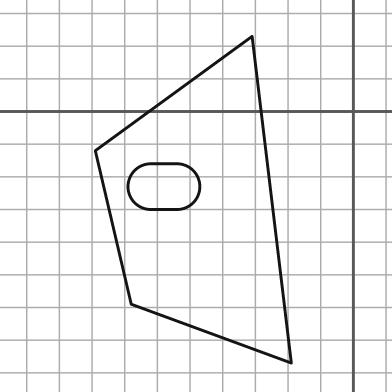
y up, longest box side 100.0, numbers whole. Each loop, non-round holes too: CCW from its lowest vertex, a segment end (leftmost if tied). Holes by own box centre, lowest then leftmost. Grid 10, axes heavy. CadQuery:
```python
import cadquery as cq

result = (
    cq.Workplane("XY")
    .moveTo(-19.0, -77.0)
    .lineTo(-31.0, 23.0)
    .lineTo(-79.0, -12.0)
    .lineTo(-68.0, -59.0)
    .close()
    .moveTo(-62.0, -30.0)
    .lineTo(-54.0, -30.0)
    .threePointArc((-47.0, -23.0), (-54.0, -16.0))
    .lineTo(-62.0, -16.0)
    .threePointArc((-69.0, -23.0), (-62.0, -30.0))
    .close()
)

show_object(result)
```